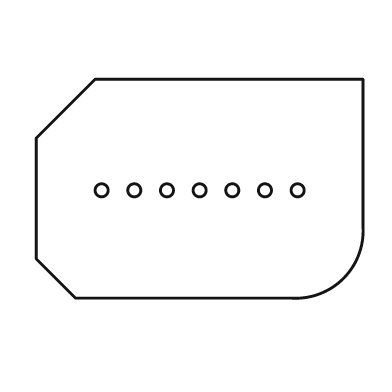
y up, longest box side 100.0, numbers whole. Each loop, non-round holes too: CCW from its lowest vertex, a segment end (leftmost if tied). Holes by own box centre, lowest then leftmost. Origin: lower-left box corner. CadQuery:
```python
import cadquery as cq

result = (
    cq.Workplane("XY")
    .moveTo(12.0, 0.0)
    .lineTo(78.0, 0.0)
    .threePointArc((94.0, 6.0), (100.0, 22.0))
    .lineTo(100.0, 67.0)
    .lineTo(18.0, 67.0)
    .lineTo(0.0, 49.0)
    .lineTo(0.0, 12.0)
    .close()
    .moveTo(20.0, 33.0)
    .circle(2.0)
    .moveTo(30.0, 33.0)
    .circle(2.0)
    .moveTo(40.0, 33.0)
    .circle(2.0)
    .moveTo(50.0, 33.0)
    .circle(2.0)
    .moveTo(60.0, 33.0)
    .circle(2.0)
    .moveTo(70.0, 33.0)
    .circle(2.0)
    .moveTo(80.0, 33.0)
    .circle(2.0)
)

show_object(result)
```